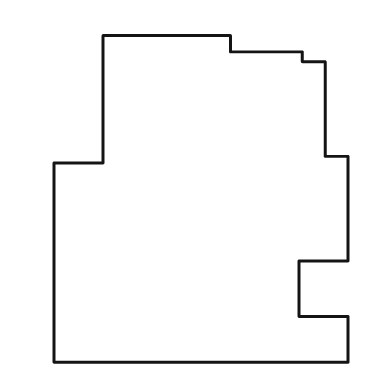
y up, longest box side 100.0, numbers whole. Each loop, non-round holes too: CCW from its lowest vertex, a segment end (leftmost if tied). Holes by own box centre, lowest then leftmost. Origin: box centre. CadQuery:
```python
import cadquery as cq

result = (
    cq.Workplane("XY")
    .moveTo(-45.0, -50.0)
    .lineTo(45.0, -50.0)
    .lineTo(45.0, -36.0)
    .lineTo(30.0, -36.0)
    .lineTo(30.0, -19.0)
    .lineTo(45.0, -19.0)
    .lineTo(45.0, 13.0)
    .lineTo(38.0, 13.0)
    .lineTo(38.0, 42.0)
    .lineTo(31.0, 42.0)
    .lineTo(31.0, 45.0)
    .lineTo(9.0, 45.0)
    .lineTo(9.0, 50.0)
    .lineTo(-30.0, 50.0)
    .lineTo(-30.0, 11.0)
    .lineTo(-45.0, 11.0)
    .close()
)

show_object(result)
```